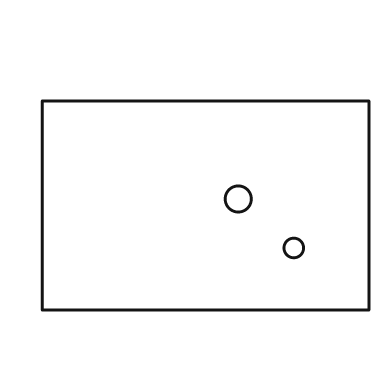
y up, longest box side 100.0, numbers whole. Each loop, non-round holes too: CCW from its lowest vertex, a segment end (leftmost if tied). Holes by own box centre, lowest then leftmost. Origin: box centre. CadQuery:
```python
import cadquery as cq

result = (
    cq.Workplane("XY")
    .moveTo(-50.0, -32.0)
    .lineTo(50.0, -32.0)
    .lineTo(50.0, 32.0)
    .lineTo(-50.0, 32.0)
    .close()
    .moveTo(27.0, -13.0)
    .circle(3.0)
    .moveTo(10.0, 2.0)
    .circle(4.0)
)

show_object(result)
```